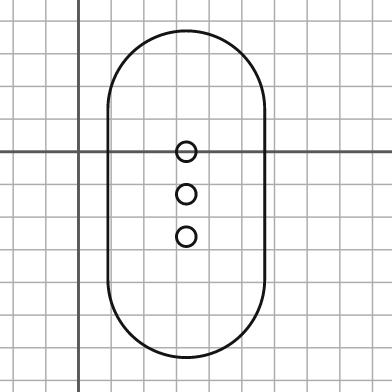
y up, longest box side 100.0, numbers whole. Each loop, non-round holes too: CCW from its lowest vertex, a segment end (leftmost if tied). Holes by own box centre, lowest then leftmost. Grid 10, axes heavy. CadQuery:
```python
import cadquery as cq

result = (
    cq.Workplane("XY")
    .moveTo(9.0, -39.0)
    .threePointArc((33.0, -63.0), (57.0, -39.0))
    .lineTo(57.0, 13.0)
    .threePointArc((33.0, 37.0), (9.0, 13.0))
    .close()
    .moveTo(33.0, -26.0)
    .circle(3.0)
    .moveTo(33.0, -13.0)
    .circle(3.0)
    .moveTo(33.0, 0.0)
    .circle(3.0)
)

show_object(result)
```